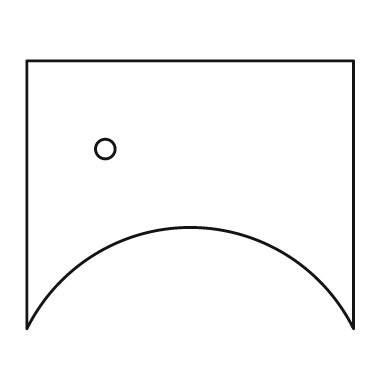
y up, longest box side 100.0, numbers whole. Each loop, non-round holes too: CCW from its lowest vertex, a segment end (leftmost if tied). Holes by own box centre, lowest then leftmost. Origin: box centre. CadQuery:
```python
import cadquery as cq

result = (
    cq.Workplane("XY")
    .moveTo(-50.0, -41.0)
    .threePointArc((0.0, -10.0), (50.0, -41.0))
    .lineTo(50.0, 41.0)
    .lineTo(-50.0, 41.0)
    .close()
    .moveTo(-26.0, 14.0)
    .circle(3.0)
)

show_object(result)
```